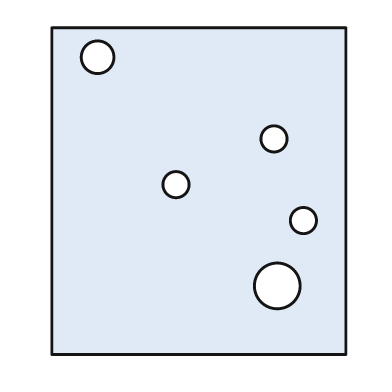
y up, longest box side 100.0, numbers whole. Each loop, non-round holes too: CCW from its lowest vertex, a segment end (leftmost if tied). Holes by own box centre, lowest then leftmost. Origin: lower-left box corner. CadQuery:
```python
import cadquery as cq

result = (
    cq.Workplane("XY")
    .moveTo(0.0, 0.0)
    .lineTo(90.0, 0.0)
    .lineTo(90.0, 100.0)
    .lineTo(0.0, 100.0)
    .close()
    .moveTo(69.0, 21.0)
    .circle(7.0)
    .moveTo(77.0, 41.0)
    .circle(4.0)
    .moveTo(38.0, 52.0)
    .circle(4.0)
    .moveTo(68.0, 66.0)
    .circle(4.0)
    .moveTo(14.0, 91.0)
    .circle(5.0)
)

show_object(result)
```